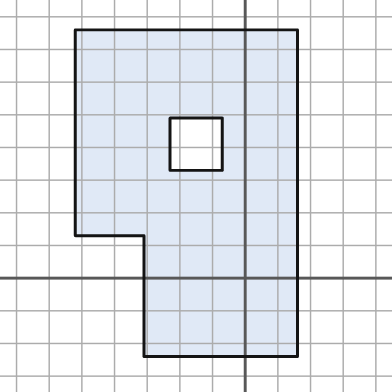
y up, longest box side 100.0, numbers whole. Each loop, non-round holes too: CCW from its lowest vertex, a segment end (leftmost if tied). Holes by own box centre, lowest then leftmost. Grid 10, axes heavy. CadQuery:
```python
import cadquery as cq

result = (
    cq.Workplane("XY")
    .moveTo(-31.0, -24.0)
    .lineTo(16.0, -24.0)
    .lineTo(16.0, 76.0)
    .lineTo(-52.0, 76.0)
    .lineTo(-52.0, 13.0)
    .lineTo(-31.0, 13.0)
    .close()
    .moveTo(-23.0, 33.0)
    .lineTo(-7.0, 33.0)
    .lineTo(-7.0, 49.0)
    .lineTo(-23.0, 49.0)
    .close()
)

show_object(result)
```